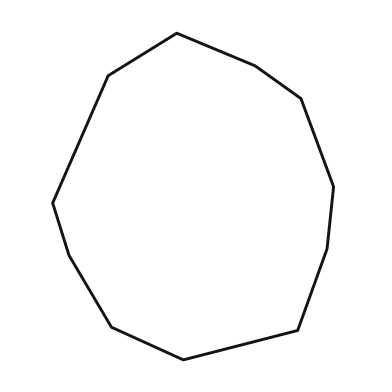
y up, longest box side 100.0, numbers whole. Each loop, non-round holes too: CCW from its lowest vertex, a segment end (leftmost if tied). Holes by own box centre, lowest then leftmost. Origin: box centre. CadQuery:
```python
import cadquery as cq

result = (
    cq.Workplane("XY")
    .moveTo(-3.0, -50.0)
    .lineTo(32.0, -41.0)
    .lineTo(41.0, -16.0)
    .lineTo(43.0, 3.0)
    .lineTo(33.0, 30.0)
    .lineTo(19.0, 40.0)
    .lineTo(-5.0, 50.0)
    .lineTo(-26.0, 37.0)
    .lineTo(-43.0, -2.0)
    .lineTo(-38.0, -18.0)
    .lineTo(-25.0, -40.0)
    .close()
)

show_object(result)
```